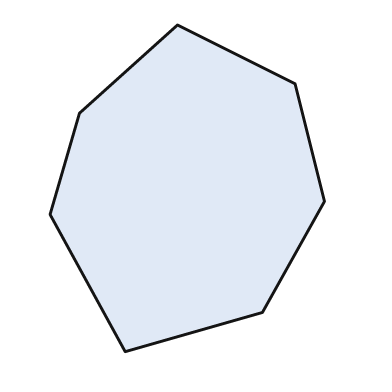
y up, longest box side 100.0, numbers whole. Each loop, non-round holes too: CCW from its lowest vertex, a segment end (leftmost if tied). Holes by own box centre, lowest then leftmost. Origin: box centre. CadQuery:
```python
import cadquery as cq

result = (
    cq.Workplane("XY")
    .moveTo(-19.0, -50.0)
    .lineTo(23.0, -38.0)
    .lineTo(42.0, -4.0)
    .lineTo(33.0, 32.0)
    .lineTo(-3.0, 50.0)
    .lineTo(-33.0, 23.0)
    .lineTo(-42.0, -8.0)
    .close()
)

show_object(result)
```